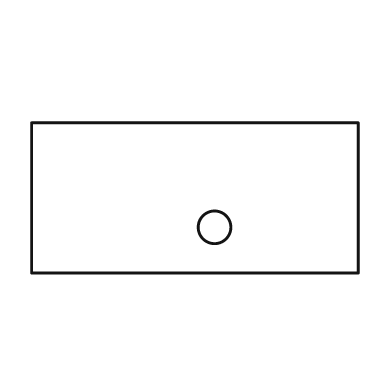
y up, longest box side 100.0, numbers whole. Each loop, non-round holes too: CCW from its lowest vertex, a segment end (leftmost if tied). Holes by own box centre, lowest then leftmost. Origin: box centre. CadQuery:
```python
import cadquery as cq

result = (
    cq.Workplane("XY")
    .moveTo(-50.0, -23.0)
    .lineTo(50.0, -23.0)
    .lineTo(50.0, 23.0)
    .lineTo(-50.0, 23.0)
    .close()
    .moveTo(6.0, -9.0)
    .circle(5.0)
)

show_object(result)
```